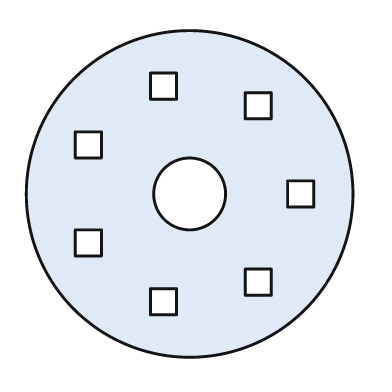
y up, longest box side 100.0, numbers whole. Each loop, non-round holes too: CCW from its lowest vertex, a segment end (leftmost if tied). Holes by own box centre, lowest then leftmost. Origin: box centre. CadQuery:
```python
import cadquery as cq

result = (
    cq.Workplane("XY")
    .moveTo(0.0, 0.0)
    .circle(50.0)
    .moveTo(-12.0, -37.0)
    .lineTo(-4.0, -37.0)
    .lineTo(-4.0, -29.0)
    .lineTo(-12.0, -29.0)
    .close()
    .moveTo(17.0, -31.0)
    .lineTo(25.0, -31.0)
    .lineTo(25.0, -23.0)
    .lineTo(17.0, -23.0)
    .close()
    .moveTo(-35.0, -19.0)
    .lineTo(-27.0, -19.0)
    .lineTo(-27.0, -11.0)
    .lineTo(-35.0, -11.0)
    .close()
    .moveTo(0.0, 0.0)
    .circle(11.0)
    .moveTo(30.0, -4.0)
    .lineTo(38.0, -4.0)
    .lineTo(38.0, 4.0)
    .lineTo(30.0, 4.0)
    .close()
    .moveTo(-35.0, 11.0)
    .lineTo(-27.0, 11.0)
    .lineTo(-27.0, 19.0)
    .lineTo(-35.0, 19.0)
    .close()
    .moveTo(17.0, 23.0)
    .lineTo(25.0, 23.0)
    .lineTo(25.0, 31.0)
    .lineTo(17.0, 31.0)
    .close()
    .moveTo(-12.0, 29.0)
    .lineTo(-4.0, 29.0)
    .lineTo(-4.0, 37.0)
    .lineTo(-12.0, 37.0)
    .close()
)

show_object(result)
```